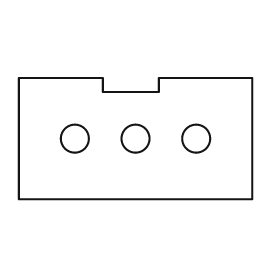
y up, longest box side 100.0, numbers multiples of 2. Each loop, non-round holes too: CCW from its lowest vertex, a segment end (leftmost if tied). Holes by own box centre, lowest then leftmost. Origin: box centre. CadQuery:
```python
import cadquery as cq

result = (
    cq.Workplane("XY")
    .moveTo(-50.0, -26.0)
    .lineTo(50.0, -26.0)
    .lineTo(50.0, 26.0)
    .lineTo(10.0, 26.0)
    .lineTo(10.0, 20.0)
    .lineTo(-14.0, 20.0)
    .lineTo(-14.0, 26.0)
    .lineTo(-50.0, 26.0)
    .close()
    .moveTo(-26.0, 0.0)
    .circle(6.0)
    .moveTo(0.0, 0.0)
    .circle(6.0)
    .moveTo(26.0, 0.0)
    .circle(6.0)
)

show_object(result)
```